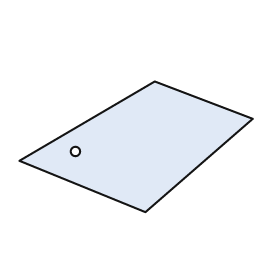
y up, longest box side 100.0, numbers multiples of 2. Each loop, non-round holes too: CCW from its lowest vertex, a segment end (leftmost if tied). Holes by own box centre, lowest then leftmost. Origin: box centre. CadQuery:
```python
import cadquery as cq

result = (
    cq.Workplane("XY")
    .moveTo(4.0, -28.0)
    .lineTo(50.0, 12.0)
    .lineTo(8.0, 28.0)
    .lineTo(-50.0, -6.0)
    .close()
    .moveTo(-26.0, -2.0)
    .circle(2.0)
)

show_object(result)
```